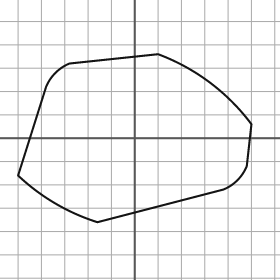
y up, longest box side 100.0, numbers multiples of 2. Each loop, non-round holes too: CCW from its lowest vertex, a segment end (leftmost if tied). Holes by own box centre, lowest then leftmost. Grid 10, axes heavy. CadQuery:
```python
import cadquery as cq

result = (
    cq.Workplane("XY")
    .moveTo(-16.0, -36.0)
    .lineTo(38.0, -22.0)
    .threePointArc((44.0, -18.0), (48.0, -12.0))
    .lineTo(50.0, 6.0)
    .threePointArc((32.0, 24.0), (10.0, 36.0))
    .lineTo(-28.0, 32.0)
    .threePointArc((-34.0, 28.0), (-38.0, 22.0))
    .lineTo(-50.0, -16.0)
    .threePointArc((-34.0, -28.0), (-16.0, -36.0))
    .close()
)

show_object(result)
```